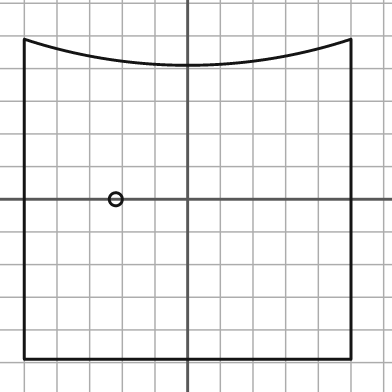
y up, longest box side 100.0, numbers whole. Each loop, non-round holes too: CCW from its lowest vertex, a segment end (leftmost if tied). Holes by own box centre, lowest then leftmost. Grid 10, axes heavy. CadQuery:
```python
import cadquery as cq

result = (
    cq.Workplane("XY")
    .moveTo(-50.0, -49.0)
    .lineTo(50.0, -49.0)
    .lineTo(50.0, 49.0)
    .threePointArc((0.0, 41.0), (-50.0, 49.0))
    .close()
    .moveTo(-22.0, 0.0)
    .circle(2.0)
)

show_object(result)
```